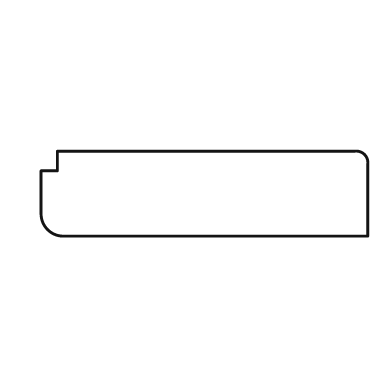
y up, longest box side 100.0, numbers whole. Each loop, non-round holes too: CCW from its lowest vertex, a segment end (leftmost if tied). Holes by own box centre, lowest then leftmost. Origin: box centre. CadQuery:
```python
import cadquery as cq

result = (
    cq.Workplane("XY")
    .moveTo(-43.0, -13.0)
    .lineTo(50.0, -13.0)
    .lineTo(50.0, 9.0)
    .threePointArc((49.0, 12.0), (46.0, 13.0))
    .lineTo(-45.0, 13.0)
    .lineTo(-45.0, 7.0)
    .lineTo(-50.0, 7.0)
    .lineTo(-50.0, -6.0)
    .threePointArc((-48.0, -11.0), (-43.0, -13.0))
    .close()
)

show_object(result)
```